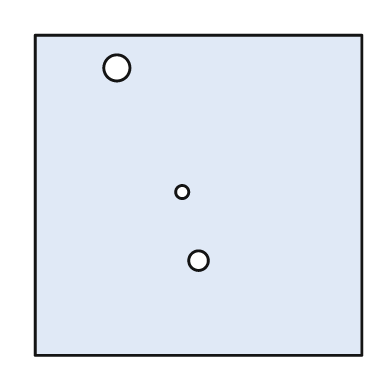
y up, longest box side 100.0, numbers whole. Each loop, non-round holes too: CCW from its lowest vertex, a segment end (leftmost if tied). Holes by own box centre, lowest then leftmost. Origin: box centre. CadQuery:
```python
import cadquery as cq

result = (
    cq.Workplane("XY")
    .moveTo(-50.0, -49.0)
    .lineTo(50.0, -49.0)
    .lineTo(50.0, 49.0)
    .lineTo(-50.0, 49.0)
    .close()
    .moveTo(0.0, -20.0)
    .circle(3.0)
    .moveTo(-5.0, 1.0)
    .circle(2.0)
    .moveTo(-25.0, 39.0)
    .circle(4.0)
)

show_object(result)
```